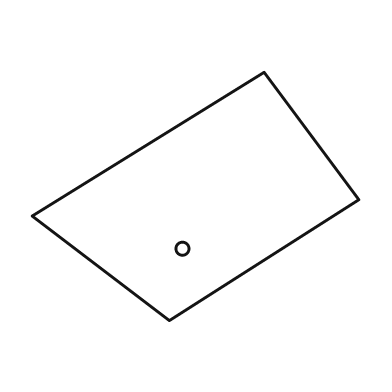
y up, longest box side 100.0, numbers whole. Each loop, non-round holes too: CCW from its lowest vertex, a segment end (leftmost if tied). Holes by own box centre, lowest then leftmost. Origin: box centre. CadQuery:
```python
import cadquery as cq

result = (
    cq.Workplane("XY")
    .moveTo(-8.0, -38.0)
    .lineTo(50.0, -1.0)
    .lineTo(21.0, 38.0)
    .lineTo(-50.0, -6.0)
    .close()
    .moveTo(-4.0, -16.0)
    .circle(2.0)
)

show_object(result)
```